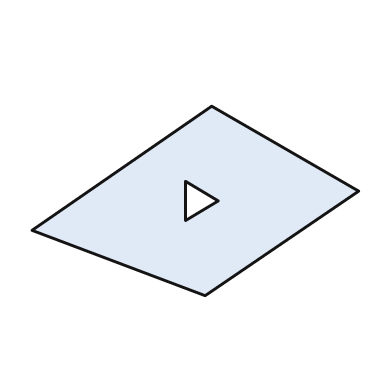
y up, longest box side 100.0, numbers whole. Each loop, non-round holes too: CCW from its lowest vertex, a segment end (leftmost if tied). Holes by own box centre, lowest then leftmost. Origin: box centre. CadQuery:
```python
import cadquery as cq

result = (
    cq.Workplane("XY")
    .moveTo(3.0, -29.0)
    .lineTo(50.0, 3.0)
    .lineTo(5.0, 29.0)
    .lineTo(-50.0, -9.0)
    .close()
    .moveTo(-3.0, -6.0)
    .lineTo(7.0, 0.0)
    .lineTo(-3.0, 6.0)
    .close()
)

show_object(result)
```